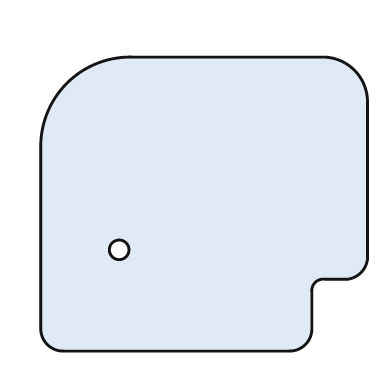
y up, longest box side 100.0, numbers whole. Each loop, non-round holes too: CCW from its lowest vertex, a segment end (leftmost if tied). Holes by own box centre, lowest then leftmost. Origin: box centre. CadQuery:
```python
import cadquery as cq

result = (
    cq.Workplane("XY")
    .moveTo(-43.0, -45.0)
    .lineTo(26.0, -45.0)
    .threePointArc((31.0, -43.0), (33.0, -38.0))
    .lineTo(33.0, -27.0)
    .threePointArc((34.0, -24.0), (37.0, -23.0))
    .lineTo(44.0, -23.0)
    .threePointArc((48.0, -21.0), (50.0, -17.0))
    .lineTo(50.0, 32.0)
    .threePointArc((46.0, 41.0), (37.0, 45.0))
    .lineTo(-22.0, 45.0)
    .threePointArc((-42.0, 37.0), (-50.0, 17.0))
    .lineTo(-50.0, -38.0)
    .threePointArc((-48.0, -43.0), (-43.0, -45.0))
    .close()
    .moveTo(-26.0, -14.0)
    .circle(3.0)
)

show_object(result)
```